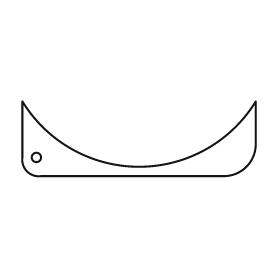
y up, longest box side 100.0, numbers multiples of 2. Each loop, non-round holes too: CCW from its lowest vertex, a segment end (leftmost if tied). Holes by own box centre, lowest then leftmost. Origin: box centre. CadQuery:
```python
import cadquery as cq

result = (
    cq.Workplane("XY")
    .moveTo(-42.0, -16.0)
    .lineTo(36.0, -16.0)
    .threePointArc((46.0, -12.0), (50.0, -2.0))
    .lineTo(50.0, 16.0)
    .threePointArc((0.0, -12.0), (-50.0, 16.0))
    .lineTo(-50.0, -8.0)
    .threePointArc((-48.0, -14.0), (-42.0, -16.0))
    .close()
    .moveTo(-44.0, -8.0)
    .circle(2.0)
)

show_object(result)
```